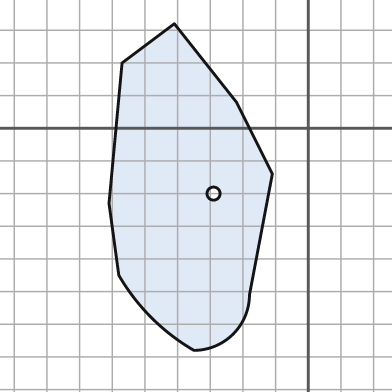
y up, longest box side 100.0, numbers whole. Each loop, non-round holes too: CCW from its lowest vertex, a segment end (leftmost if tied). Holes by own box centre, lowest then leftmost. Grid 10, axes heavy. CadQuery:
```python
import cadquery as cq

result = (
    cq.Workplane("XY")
    .moveTo(-35.0, -68.0)
    .threePointArc((-23.0, -63.0), (-18.0, -51.0))
    .lineTo(-11.0, -14.0)
    .lineTo(-22.0, 8.0)
    .lineTo(-41.0, 32.0)
    .lineTo(-57.0, 20.0)
    .lineTo(-61.0, -23.0)
    .lineTo(-58.0, -45.0)
    .threePointArc((-48.0, -58.0), (-35.0, -68.0))
    .close()
    .moveTo(-29.0, -20.0)
    .circle(2.0)
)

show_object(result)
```